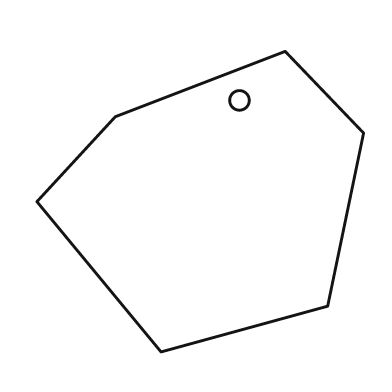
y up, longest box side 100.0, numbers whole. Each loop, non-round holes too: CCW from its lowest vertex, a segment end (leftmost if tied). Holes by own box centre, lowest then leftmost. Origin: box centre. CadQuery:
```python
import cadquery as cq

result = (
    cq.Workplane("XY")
    .moveTo(-12.0, -46.0)
    .lineTo(39.0, -32.0)
    .lineTo(50.0, 21.0)
    .lineTo(26.0, 46.0)
    .lineTo(-26.0, 26.0)
    .lineTo(-50.0, 0.0)
    .close()
    .moveTo(12.0, 31.0)
    .circle(3.0)
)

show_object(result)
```